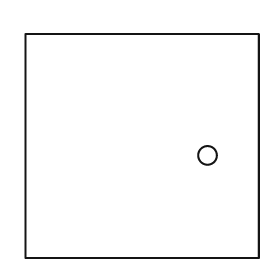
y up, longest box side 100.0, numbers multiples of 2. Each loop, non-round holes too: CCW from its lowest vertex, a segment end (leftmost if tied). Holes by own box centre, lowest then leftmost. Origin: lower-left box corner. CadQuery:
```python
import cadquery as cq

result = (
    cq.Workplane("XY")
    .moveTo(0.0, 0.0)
    .lineTo(100.0, 0.0)
    .lineTo(100.0, 96.0)
    .lineTo(0.0, 96.0)
    .close()
    .moveTo(78.0, 44.0)
    .circle(4.0)
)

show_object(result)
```